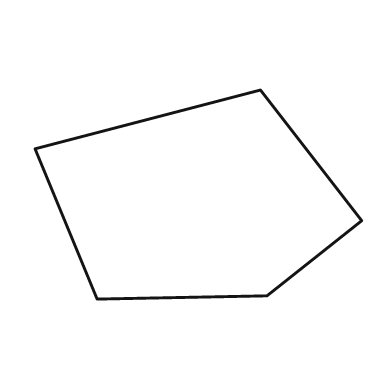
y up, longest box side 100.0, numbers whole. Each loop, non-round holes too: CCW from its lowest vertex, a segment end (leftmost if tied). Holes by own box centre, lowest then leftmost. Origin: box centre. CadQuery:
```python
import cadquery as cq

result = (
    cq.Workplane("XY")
    .moveTo(-31.0, -32.0)
    .lineTo(21.0, -31.0)
    .lineTo(50.0, -8.0)
    .lineTo(19.0, 32.0)
    .lineTo(-50.0, 14.0)
    .close()
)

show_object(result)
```